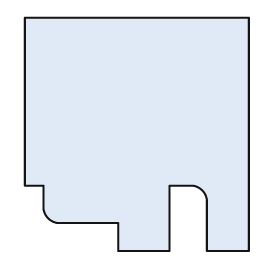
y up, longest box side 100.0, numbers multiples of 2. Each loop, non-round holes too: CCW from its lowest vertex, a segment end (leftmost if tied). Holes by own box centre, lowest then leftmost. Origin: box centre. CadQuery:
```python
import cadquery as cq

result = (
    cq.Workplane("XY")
    .moveTo(-8.0, -50.0)
    .lineTo(14.0, -50.0)
    .lineTo(14.0, -22.0)
    .lineTo(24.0, -22.0)
    .threePointArc((28.0, -24.0), (30.0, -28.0))
    .lineTo(30.0, -50.0)
    .lineTo(48.0, -50.0)
    .lineTo(48.0, 50.0)
    .lineTo(-48.0, 50.0)
    .lineTo(-48.0, -22.0)
    .lineTo(-40.0, -22.0)
    .lineTo(-40.0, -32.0)
    .threePointArc((-38.0, -36.0), (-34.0, -38.0))
    .lineTo(-8.0, -38.0)
    .close()
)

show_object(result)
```